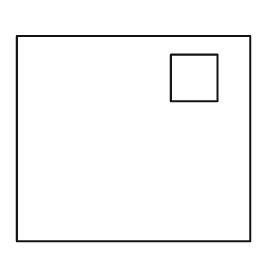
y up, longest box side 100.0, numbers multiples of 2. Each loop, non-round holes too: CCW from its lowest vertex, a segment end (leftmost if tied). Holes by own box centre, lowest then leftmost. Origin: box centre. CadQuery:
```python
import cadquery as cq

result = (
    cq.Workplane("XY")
    .moveTo(-50.0, -44.0)
    .lineTo(50.0, -44.0)
    .lineTo(50.0, 44.0)
    .lineTo(-50.0, 44.0)
    .close()
    .moveTo(16.0, 16.0)
    .lineTo(36.0, 16.0)
    .lineTo(36.0, 36.0)
    .lineTo(16.0, 36.0)
    .close()
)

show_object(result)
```